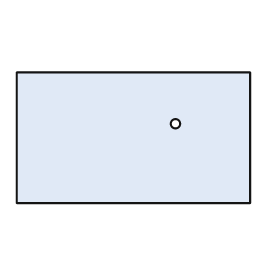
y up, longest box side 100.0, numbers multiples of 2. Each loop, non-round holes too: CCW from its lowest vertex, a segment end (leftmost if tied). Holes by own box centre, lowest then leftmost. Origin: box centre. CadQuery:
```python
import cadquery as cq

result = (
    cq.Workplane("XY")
    .moveTo(-50.0, -28.0)
    .lineTo(50.0, -28.0)
    .lineTo(50.0, 28.0)
    .lineTo(-50.0, 28.0)
    .close()
    .moveTo(18.0, 6.0)
    .circle(2.0)
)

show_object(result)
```